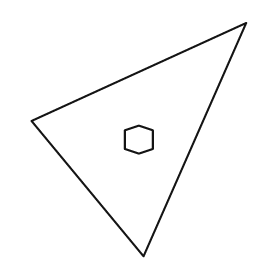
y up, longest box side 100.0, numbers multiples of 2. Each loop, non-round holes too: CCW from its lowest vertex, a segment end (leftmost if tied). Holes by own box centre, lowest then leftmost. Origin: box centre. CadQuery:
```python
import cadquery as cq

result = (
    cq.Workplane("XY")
    .moveTo(2.0, -50.0)
    .lineTo(46.0, 50.0)
    .lineTo(-46.0, 8.0)
    .close()
    .moveTo(0.0, -6.0)
    .lineTo(6.0, -4.0)
    .lineTo(6.0, 4.0)
    .lineTo(0.0, 6.0)
    .lineTo(-6.0, 4.0)
    .lineTo(-6.0, -4.0)
    .close()
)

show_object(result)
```